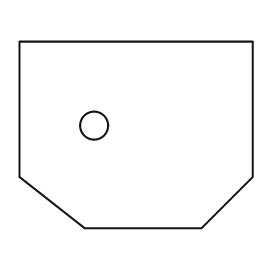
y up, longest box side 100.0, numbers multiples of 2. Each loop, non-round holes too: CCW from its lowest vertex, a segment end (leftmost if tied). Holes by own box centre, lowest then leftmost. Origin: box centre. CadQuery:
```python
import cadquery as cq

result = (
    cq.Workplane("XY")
    .moveTo(-22.0, -40.0)
    .lineTo(28.0, -40.0)
    .lineTo(50.0, -18.0)
    .lineTo(50.0, 40.0)
    .lineTo(-50.0, 40.0)
    .lineTo(-50.0, -18.0)
    .close()
    .moveTo(-18.0, 4.0)
    .circle(6.0)
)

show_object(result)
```